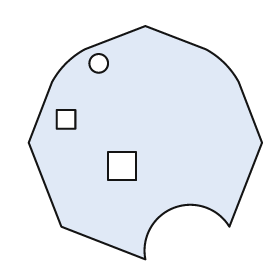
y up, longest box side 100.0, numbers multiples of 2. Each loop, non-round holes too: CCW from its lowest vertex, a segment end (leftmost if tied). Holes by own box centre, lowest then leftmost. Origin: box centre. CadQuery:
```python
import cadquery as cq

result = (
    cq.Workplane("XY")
    .moveTo(0.0, -50.0)
    .threePointArc((12.0, -28.0), (36.0, -36.0))
    .lineTo(50.0, 0.0)
    .lineTo(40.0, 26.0)
    .threePointArc((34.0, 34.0), (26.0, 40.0))
    .lineTo(0.0, 50.0)
    .lineTo(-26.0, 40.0)
    .threePointArc((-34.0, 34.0), (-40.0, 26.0))
    .lineTo(-50.0, 0.0)
    .lineTo(-36.0, -36.0)
    .close()
    .moveTo(-16.0, -16.0)
    .lineTo(-4.0, -16.0)
    .lineTo(-4.0, -4.0)
    .lineTo(-16.0, -4.0)
    .close()
    .moveTo(-38.0, 6.0)
    .lineTo(-30.0, 6.0)
    .lineTo(-30.0, 14.0)
    .lineTo(-38.0, 14.0)
    .close()
    .moveTo(-20.0, 34.0)
    .circle(4.0)
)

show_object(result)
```